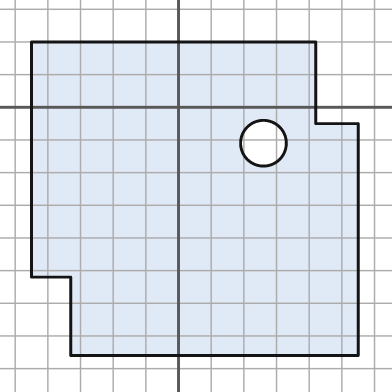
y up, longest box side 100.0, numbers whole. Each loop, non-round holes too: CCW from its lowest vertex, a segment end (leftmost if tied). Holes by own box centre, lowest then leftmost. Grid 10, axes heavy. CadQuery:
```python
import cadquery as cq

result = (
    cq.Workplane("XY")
    .moveTo(-33.0, -76.0)
    .lineTo(55.0, -76.0)
    .lineTo(55.0, -5.0)
    .lineTo(42.0, -5.0)
    .lineTo(42.0, 20.0)
    .lineTo(-45.0, 20.0)
    .lineTo(-45.0, -52.0)
    .lineTo(-33.0, -52.0)
    .close()
    .moveTo(26.0, -11.0)
    .circle(7.0)
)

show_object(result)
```